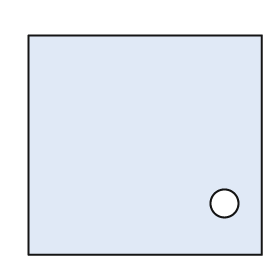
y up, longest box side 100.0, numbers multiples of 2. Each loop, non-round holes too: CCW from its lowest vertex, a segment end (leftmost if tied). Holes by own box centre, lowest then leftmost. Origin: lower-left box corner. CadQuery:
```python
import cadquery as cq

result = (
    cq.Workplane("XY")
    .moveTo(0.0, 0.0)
    .lineTo(100.0, 0.0)
    .lineTo(100.0, 94.0)
    .lineTo(0.0, 94.0)
    .close()
    .moveTo(84.0, 22.0)
    .circle(6.0)
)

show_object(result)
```